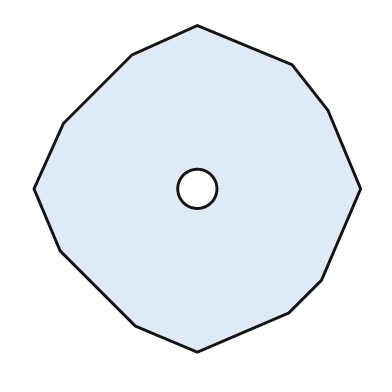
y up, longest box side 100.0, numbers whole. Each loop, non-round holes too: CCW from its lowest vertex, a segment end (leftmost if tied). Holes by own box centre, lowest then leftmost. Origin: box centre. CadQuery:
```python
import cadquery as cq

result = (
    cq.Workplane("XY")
    .moveTo(0.0, -50.0)
    .lineTo(28.0, -38.0)
    .lineTo(38.0, -28.0)
    .lineTo(50.0, 0.0)
    .lineTo(40.0, 24.0)
    .lineTo(29.0, 38.0)
    .lineTo(0.0, 50.0)
    .lineTo(-20.0, 41.0)
    .lineTo(-41.0, 20.0)
    .lineTo(-50.0, 0.0)
    .lineTo(-42.0, -19.0)
    .lineTo(-19.0, -42.0)
    .close()
    .moveTo(0.0, 0.0)
    .circle(6.0)
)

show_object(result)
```